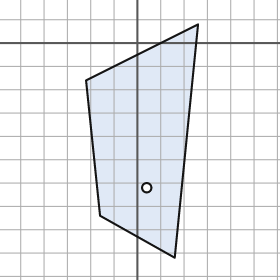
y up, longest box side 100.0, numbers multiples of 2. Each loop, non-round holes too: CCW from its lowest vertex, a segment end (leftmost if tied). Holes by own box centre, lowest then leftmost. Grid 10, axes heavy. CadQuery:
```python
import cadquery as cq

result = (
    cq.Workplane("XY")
    .moveTo(16.0, -92.0)
    .lineTo(26.0, 8.0)
    .lineTo(-22.0, -16.0)
    .lineTo(-16.0, -74.0)
    .close()
    .moveTo(4.0, -62.0)
    .circle(2.0)
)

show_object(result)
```